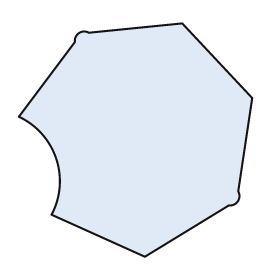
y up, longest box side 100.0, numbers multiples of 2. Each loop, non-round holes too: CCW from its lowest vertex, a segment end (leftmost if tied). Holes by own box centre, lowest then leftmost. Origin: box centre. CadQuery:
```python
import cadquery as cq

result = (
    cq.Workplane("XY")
    .moveTo(4.0, -50.0)
    .lineTo(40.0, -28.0)
    .threePointArc((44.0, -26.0), (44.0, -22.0))
    .lineTo(50.0, 18.0)
    .lineTo(20.0, 50.0)
    .lineTo(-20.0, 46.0)
    .threePointArc((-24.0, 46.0), (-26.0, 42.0))
    .lineTo(-50.0, 10.0)
    .threePointArc((-34.0, -8.0), (-36.0, -32.0))
    .close()
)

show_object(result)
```